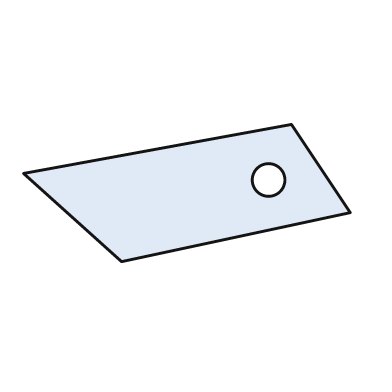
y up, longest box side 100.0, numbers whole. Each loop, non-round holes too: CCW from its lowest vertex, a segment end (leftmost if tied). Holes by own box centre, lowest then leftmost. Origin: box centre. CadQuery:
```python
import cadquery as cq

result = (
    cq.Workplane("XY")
    .moveTo(-20.0, -21.0)
    .lineTo(50.0, -6.0)
    .lineTo(32.0, 21.0)
    .lineTo(-50.0, 6.0)
    .close()
    .moveTo(25.0, 4.0)
    .circle(5.0)
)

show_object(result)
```